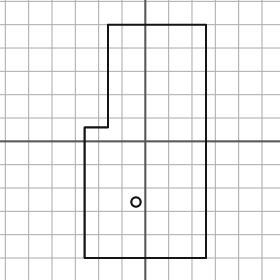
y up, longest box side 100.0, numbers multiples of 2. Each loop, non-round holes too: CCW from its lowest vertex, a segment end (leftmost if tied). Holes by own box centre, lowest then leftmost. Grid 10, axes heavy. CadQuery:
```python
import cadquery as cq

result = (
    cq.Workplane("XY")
    .moveTo(-26.0, -50.0)
    .lineTo(26.0, -50.0)
    .lineTo(26.0, 50.0)
    .lineTo(-16.0, 50.0)
    .lineTo(-16.0, 6.0)
    .lineTo(-26.0, 6.0)
    .close()
    .moveTo(-4.0, -26.0)
    .circle(2.0)
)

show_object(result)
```